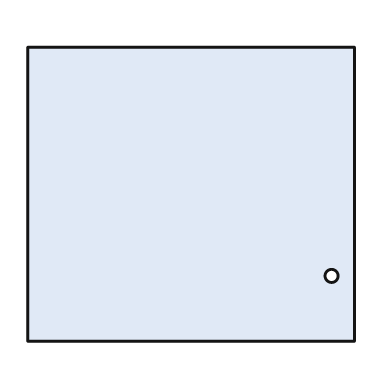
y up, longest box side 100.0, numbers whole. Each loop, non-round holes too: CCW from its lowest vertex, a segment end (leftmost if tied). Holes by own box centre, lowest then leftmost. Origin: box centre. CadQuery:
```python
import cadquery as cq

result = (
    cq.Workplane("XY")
    .moveTo(-50.0, -45.0)
    .lineTo(50.0, -45.0)
    .lineTo(50.0, 45.0)
    .lineTo(-50.0, 45.0)
    .close()
    .moveTo(43.0, -25.0)
    .circle(2.0)
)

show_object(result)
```